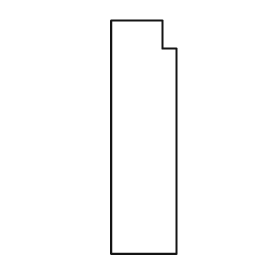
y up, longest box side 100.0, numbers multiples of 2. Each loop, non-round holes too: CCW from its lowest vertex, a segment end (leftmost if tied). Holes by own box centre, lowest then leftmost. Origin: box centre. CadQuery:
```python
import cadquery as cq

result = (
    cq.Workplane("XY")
    .moveTo(-14.0, -50.0)
    .lineTo(14.0, -50.0)
    .lineTo(14.0, 38.0)
    .lineTo(8.0, 38.0)
    .lineTo(8.0, 50.0)
    .lineTo(-14.0, 50.0)
    .close()
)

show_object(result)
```